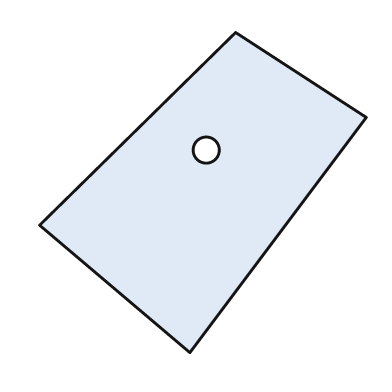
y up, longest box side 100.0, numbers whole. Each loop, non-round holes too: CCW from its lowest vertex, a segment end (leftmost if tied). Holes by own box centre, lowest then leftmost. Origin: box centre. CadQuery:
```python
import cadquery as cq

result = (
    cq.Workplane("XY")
    .moveTo(-4.0, -49.0)
    .lineTo(50.0, 23.0)
    .lineTo(10.0, 49.0)
    .lineTo(-50.0, -10.0)
    .close()
    .moveTo(1.0, 13.0)
    .circle(4.0)
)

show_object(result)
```